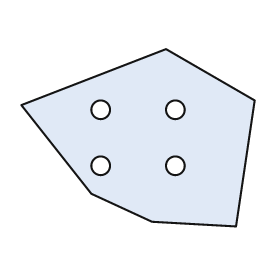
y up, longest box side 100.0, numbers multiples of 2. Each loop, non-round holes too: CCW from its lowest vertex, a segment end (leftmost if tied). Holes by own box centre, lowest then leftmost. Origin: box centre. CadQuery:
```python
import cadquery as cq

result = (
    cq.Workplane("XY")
    .moveTo(42.0, -38.0)
    .lineTo(50.0, 16.0)
    .lineTo(12.0, 38.0)
    .lineTo(-50.0, 14.0)
    .lineTo(-20.0, -24.0)
    .lineTo(6.0, -36.0)
    .close()
    .moveTo(-16.0, -12.0)
    .circle(4.0)
    .moveTo(16.0, -12.0)
    .circle(4.0)
    .moveTo(-16.0, 12.0)
    .circle(4.0)
    .moveTo(16.0, 12.0)
    .circle(4.0)
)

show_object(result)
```